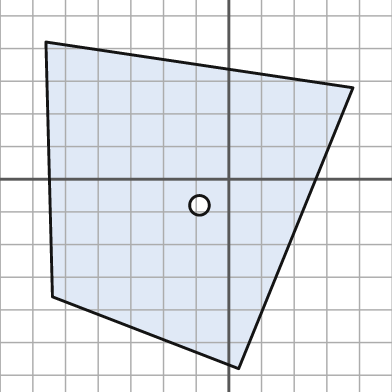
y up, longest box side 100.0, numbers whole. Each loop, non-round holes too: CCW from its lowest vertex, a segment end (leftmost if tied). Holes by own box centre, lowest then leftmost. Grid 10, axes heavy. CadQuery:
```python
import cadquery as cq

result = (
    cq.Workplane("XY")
    .moveTo(3.0, -58.0)
    .lineTo(38.0, 28.0)
    .lineTo(-56.0, 42.0)
    .lineTo(-54.0, -36.0)
    .close()
    .moveTo(-9.0, -8.0)
    .circle(3.0)
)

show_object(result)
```